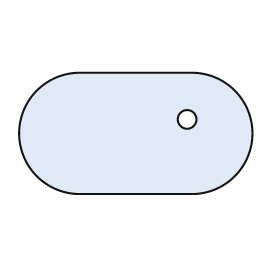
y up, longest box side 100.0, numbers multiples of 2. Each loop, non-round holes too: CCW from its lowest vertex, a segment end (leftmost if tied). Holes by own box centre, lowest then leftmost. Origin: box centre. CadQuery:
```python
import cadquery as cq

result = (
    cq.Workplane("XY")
    .moveTo(-24.0, -26.0)
    .lineTo(24.0, -26.0)
    .threePointArc((50.0, 0.0), (24.0, 26.0))
    .lineTo(-24.0, 26.0)
    .threePointArc((-50.0, 0.0), (-24.0, -26.0))
    .close()
    .moveTo(22.0, 6.0)
    .circle(4.0)
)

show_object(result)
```